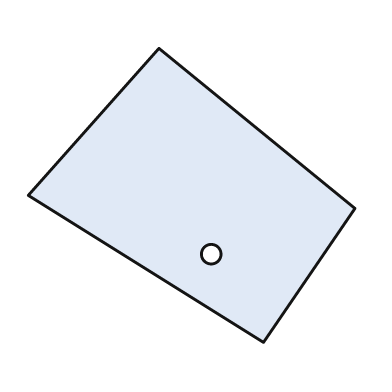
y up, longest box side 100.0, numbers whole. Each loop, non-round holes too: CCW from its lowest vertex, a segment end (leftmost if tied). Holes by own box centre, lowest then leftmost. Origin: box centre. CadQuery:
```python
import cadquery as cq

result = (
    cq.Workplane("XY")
    .moveTo(22.0, -45.0)
    .lineTo(50.0, -4.0)
    .lineTo(-10.0, 45.0)
    .lineTo(-50.0, 0.0)
    .close()
    .moveTo(6.0, -18.0)
    .circle(3.0)
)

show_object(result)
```